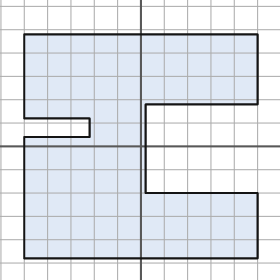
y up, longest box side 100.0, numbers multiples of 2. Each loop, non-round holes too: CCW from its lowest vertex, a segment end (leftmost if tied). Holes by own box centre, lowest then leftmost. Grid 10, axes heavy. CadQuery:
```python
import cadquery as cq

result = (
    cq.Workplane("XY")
    .moveTo(-50.0, -48.0)
    .lineTo(50.0, -48.0)
    .lineTo(50.0, -20.0)
    .lineTo(2.0, -20.0)
    .lineTo(2.0, 18.0)
    .lineTo(50.0, 18.0)
    .lineTo(50.0, 48.0)
    .lineTo(-50.0, 48.0)
    .lineTo(-50.0, 12.0)
    .lineTo(-22.0, 12.0)
    .lineTo(-22.0, 4.0)
    .lineTo(-50.0, 4.0)
    .close()
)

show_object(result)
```